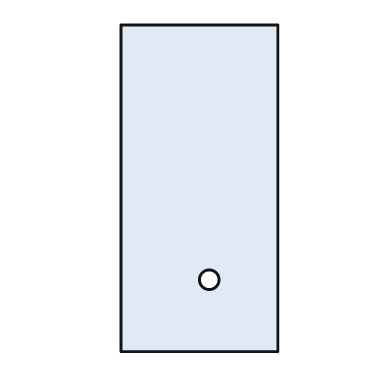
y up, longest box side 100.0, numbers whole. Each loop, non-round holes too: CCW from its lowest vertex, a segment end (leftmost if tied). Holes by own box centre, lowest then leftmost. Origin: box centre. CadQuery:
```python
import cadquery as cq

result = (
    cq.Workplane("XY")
    .moveTo(-24.0, -50.0)
    .lineTo(24.0, -50.0)
    .lineTo(24.0, 50.0)
    .lineTo(-24.0, 50.0)
    .close()
    .moveTo(3.0, -28.0)
    .circle(3.0)
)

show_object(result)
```